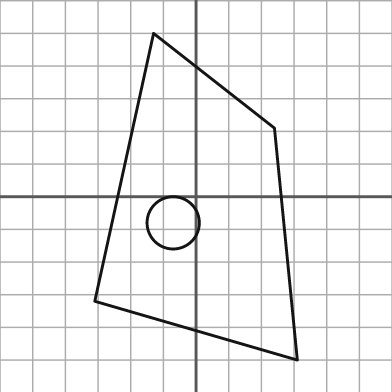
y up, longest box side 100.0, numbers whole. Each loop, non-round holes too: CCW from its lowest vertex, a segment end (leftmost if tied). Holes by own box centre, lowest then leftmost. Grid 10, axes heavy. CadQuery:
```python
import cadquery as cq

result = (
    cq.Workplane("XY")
    .moveTo(31.0, -50.0)
    .lineTo(24.0, 21.0)
    .lineTo(-13.0, 50.0)
    .lineTo(-31.0, -32.0)
    .close()
    .moveTo(-7.0, -8.0)
    .circle(8.0)
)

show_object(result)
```